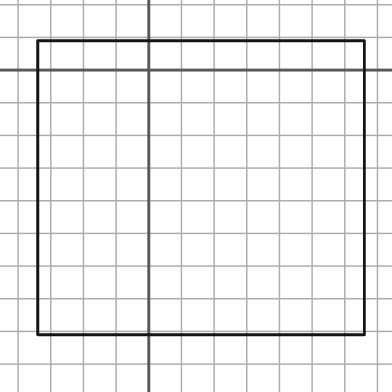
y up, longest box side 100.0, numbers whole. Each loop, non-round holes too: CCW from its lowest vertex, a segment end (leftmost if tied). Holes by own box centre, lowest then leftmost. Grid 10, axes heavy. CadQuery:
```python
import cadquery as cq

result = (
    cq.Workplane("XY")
    .moveTo(-34.0, -81.0)
    .lineTo(66.0, -81.0)
    .lineTo(66.0, 9.0)
    .lineTo(-34.0, 9.0)
    .close()
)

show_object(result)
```